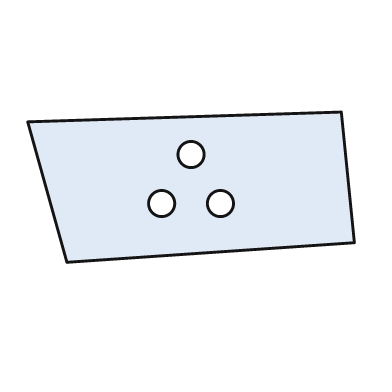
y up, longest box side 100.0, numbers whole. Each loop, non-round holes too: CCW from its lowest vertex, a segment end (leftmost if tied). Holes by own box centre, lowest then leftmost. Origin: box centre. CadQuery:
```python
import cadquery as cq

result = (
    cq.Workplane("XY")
    .moveTo(-38.0, -23.0)
    .lineTo(50.0, -17.0)
    .lineTo(46.0, 23.0)
    .lineTo(-50.0, 20.0)
    .close()
    .moveTo(-9.0, -5.0)
    .circle(4.0)
    .moveTo(9.0, -5.0)
    .circle(4.0)
    .moveTo(0.0, 10.0)
    .circle(4.0)
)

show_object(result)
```